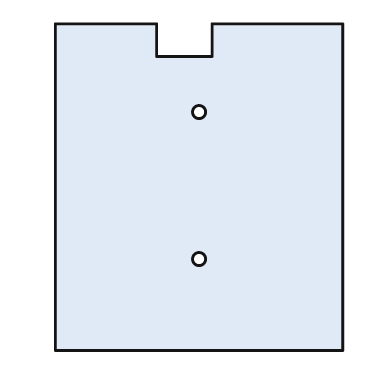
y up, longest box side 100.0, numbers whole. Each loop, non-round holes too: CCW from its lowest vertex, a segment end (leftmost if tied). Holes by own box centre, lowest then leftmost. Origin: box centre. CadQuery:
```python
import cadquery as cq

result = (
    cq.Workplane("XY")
    .moveTo(-44.0, -50.0)
    .lineTo(44.0, -50.0)
    .lineTo(44.0, 50.0)
    .lineTo(4.0, 50.0)
    .lineTo(4.0, 40.0)
    .lineTo(-13.0, 40.0)
    .lineTo(-13.0, 50.0)
    .lineTo(-44.0, 50.0)
    .close()
    .moveTo(0.0, -22.0)
    .circle(2.0)
    .moveTo(0.0, 23.0)
    .circle(2.0)
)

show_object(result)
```